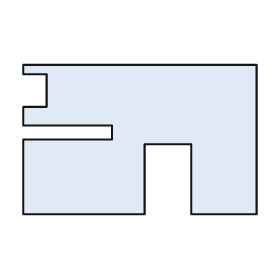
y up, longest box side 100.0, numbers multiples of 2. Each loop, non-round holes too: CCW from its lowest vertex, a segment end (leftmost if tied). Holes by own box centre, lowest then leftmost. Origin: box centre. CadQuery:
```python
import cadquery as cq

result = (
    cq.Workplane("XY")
    .moveTo(-50.0, -32.0)
    .lineTo(2.0, -32.0)
    .lineTo(2.0, -2.0)
    .lineTo(22.0, -2.0)
    .lineTo(22.0, -32.0)
    .lineTo(50.0, -32.0)
    .lineTo(50.0, 32.0)
    .lineTo(-50.0, 32.0)
    .lineTo(-50.0, 28.0)
    .lineTo(-40.0, 28.0)
    .lineTo(-40.0, 14.0)
    .lineTo(-50.0, 14.0)
    .lineTo(-50.0, 6.0)
    .lineTo(-12.0, 6.0)
    .lineTo(-12.0, 0.0)
    .lineTo(-50.0, 0.0)
    .close()
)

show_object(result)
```